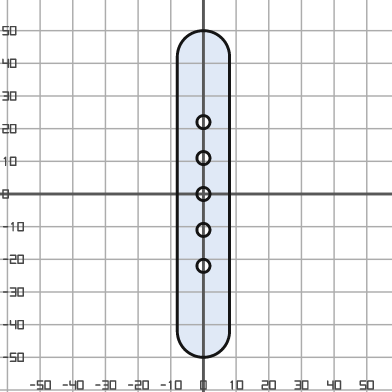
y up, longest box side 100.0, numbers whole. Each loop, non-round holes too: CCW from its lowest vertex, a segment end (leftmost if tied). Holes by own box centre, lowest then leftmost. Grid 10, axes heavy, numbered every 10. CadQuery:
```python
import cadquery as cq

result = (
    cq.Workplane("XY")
    .moveTo(-8.0, -42.0)
    .threePointArc((0.0, -50.0), (8.0, -42.0))
    .lineTo(8.0, 42.0)
    .threePointArc((0.0, 50.0), (-8.0, 42.0))
    .close()
    .moveTo(0.0, -22.0)
    .circle(2.0)
    .moveTo(0.0, -11.0)
    .circle(2.0)
    .moveTo(0.0, 0.0)
    .circle(2.0)
    .moveTo(0.0, 11.0)
    .circle(2.0)
    .moveTo(0.0, 22.0)
    .circle(2.0)
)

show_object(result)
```